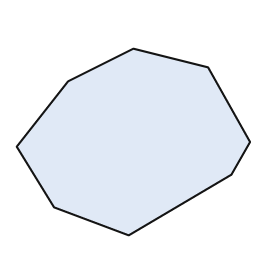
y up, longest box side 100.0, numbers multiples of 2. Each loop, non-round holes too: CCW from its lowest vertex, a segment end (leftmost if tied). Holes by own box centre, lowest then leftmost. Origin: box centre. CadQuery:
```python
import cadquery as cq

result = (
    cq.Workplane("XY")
    .moveTo(-2.0, -40.0)
    .lineTo(42.0, -14.0)
    .lineTo(50.0, 0.0)
    .lineTo(32.0, 32.0)
    .lineTo(0.0, 40.0)
    .lineTo(-28.0, 26.0)
    .lineTo(-50.0, -2.0)
    .lineTo(-34.0, -28.0)
    .close()
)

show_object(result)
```